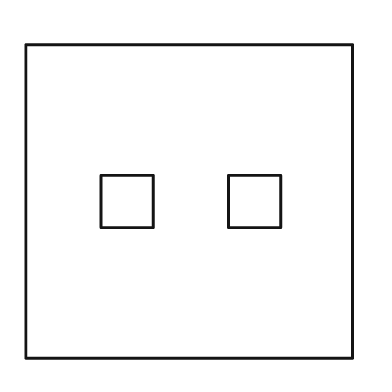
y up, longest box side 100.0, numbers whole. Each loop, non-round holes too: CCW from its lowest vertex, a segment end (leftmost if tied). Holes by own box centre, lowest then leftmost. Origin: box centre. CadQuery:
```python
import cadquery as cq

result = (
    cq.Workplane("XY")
    .moveTo(-50.0, -48.0)
    .lineTo(50.0, -48.0)
    .lineTo(50.0, 48.0)
    .lineTo(-50.0, 48.0)
    .close()
    .moveTo(-27.0, -8.0)
    .lineTo(-11.0, -8.0)
    .lineTo(-11.0, 8.0)
    .lineTo(-27.0, 8.0)
    .close()
    .moveTo(12.0, -8.0)
    .lineTo(28.0, -8.0)
    .lineTo(28.0, 8.0)
    .lineTo(12.0, 8.0)
    .close()
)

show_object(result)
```